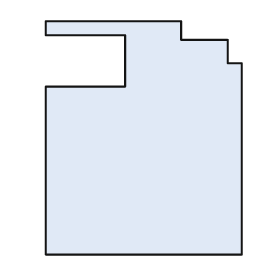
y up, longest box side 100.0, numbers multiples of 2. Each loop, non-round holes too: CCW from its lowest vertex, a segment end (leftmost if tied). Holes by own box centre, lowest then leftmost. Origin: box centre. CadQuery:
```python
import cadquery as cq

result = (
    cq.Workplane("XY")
    .moveTo(-42.0, -50.0)
    .lineTo(42.0, -50.0)
    .lineTo(42.0, 32.0)
    .lineTo(36.0, 32.0)
    .lineTo(36.0, 42.0)
    .lineTo(16.0, 42.0)
    .lineTo(16.0, 50.0)
    .lineTo(-42.0, 50.0)
    .lineTo(-42.0, 44.0)
    .lineTo(-8.0, 44.0)
    .lineTo(-8.0, 22.0)
    .lineTo(-42.0, 22.0)
    .close()
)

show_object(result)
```